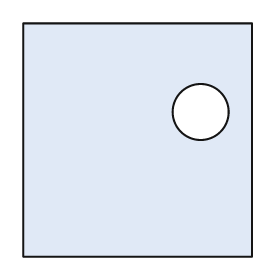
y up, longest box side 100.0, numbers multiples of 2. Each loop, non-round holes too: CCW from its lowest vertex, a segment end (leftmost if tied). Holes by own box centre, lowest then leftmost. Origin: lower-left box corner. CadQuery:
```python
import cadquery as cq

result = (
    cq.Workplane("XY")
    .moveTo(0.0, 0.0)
    .lineTo(98.0, 0.0)
    .lineTo(98.0, 100.0)
    .lineTo(0.0, 100.0)
    .close()
    .moveTo(76.0, 62.0)
    .circle(12.0)
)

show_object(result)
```